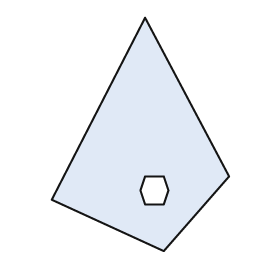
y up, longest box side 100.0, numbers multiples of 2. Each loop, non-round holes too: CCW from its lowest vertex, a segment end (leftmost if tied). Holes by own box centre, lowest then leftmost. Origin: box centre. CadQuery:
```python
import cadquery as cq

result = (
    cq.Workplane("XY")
    .moveTo(10.0, -50.0)
    .lineTo(38.0, -18.0)
    .lineTo(2.0, 50.0)
    .lineTo(-38.0, -28.0)
    .close()
    .moveTo(2.0, -30.0)
    .lineTo(10.0, -30.0)
    .lineTo(12.0, -24.0)
    .lineTo(10.0, -18.0)
    .lineTo(2.0, -18.0)
    .lineTo(0.0, -24.0)
    .close()
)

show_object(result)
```